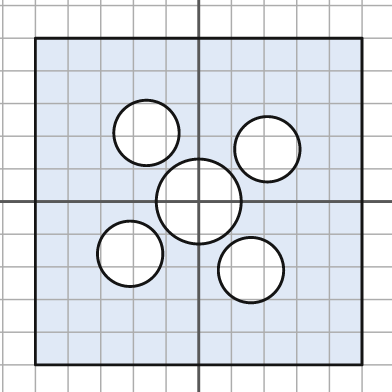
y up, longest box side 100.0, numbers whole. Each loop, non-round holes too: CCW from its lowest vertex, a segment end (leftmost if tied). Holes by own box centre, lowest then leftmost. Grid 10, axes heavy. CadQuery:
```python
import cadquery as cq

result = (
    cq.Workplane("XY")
    .moveTo(-50.0, -50.0)
    .lineTo(50.0, -50.0)
    .lineTo(50.0, 50.0)
    .lineTo(-50.0, 50.0)
    .close()
    .moveTo(16.0, -21.0)
    .circle(10.0)
    .moveTo(-21.0, -16.0)
    .circle(10.0)
    .moveTo(0.0, 0.0)
    .circle(13.0)
    .moveTo(21.0, 16.0)
    .circle(10.0)
    .moveTo(-16.0, 21.0)
    .circle(10.0)
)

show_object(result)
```